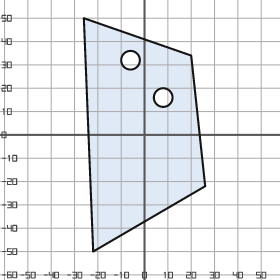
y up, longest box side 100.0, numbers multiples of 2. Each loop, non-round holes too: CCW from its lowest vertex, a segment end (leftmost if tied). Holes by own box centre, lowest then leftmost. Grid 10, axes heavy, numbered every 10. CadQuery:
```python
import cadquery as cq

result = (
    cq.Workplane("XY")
    .moveTo(-22.0, -50.0)
    .lineTo(26.0, -22.0)
    .lineTo(20.0, 34.0)
    .lineTo(-26.0, 50.0)
    .close()
    .moveTo(8.0, 16.0)
    .circle(4.0)
    .moveTo(-6.0, 32.0)
    .circle(4.0)
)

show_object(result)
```